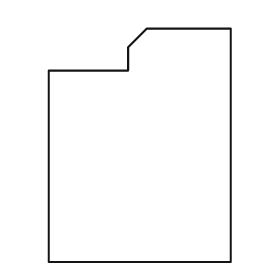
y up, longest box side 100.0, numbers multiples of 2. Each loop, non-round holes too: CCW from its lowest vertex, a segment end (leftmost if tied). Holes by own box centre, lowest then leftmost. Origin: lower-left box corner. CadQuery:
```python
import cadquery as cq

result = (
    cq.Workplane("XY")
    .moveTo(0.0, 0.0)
    .lineTo(78.0, 0.0)
    .lineTo(78.0, 100.0)
    .lineTo(42.0, 100.0)
    .lineTo(34.0, 92.0)
    .lineTo(34.0, 82.0)
    .lineTo(0.0, 82.0)
    .close()
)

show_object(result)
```